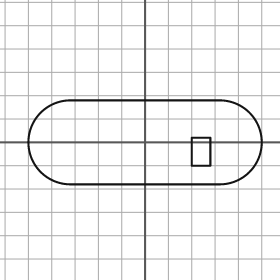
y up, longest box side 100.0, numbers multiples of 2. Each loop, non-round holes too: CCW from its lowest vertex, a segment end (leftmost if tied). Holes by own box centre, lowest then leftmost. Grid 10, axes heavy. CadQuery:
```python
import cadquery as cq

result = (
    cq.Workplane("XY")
    .moveTo(-32.0, -18.0)
    .lineTo(32.0, -18.0)
    .threePointArc((50.0, 0.0), (32.0, 18.0))
    .lineTo(-32.0, 18.0)
    .threePointArc((-50.0, 0.0), (-32.0, -18.0))
    .close()
    .moveTo(20.0, -10.0)
    .lineTo(28.0, -10.0)
    .lineTo(28.0, 2.0)
    .lineTo(20.0, 2.0)
    .close()
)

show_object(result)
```